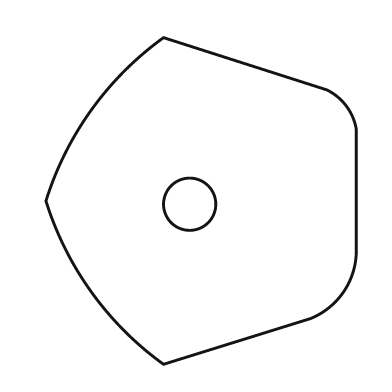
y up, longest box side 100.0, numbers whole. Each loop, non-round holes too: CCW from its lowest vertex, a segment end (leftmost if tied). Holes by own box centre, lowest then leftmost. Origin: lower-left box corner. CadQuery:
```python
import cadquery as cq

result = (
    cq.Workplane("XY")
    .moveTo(36.0, 0.0)
    .lineTo(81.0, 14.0)
    .threePointArc((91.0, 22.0), (95.0, 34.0))
    .lineTo(95.0, 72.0)
    .threePointArc((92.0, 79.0), (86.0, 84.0))
    .lineTo(36.0, 100.0)
    .threePointArc((14.0, 78.0), (0.0, 50.0))
    .threePointArc((14.0, 22.0), (36.0, 0.0))
    .close()
    .moveTo(44.0, 49.0)
    .circle(8.0)
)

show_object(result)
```